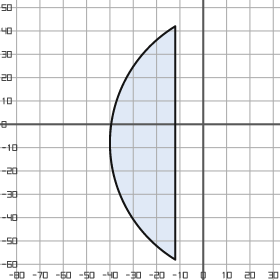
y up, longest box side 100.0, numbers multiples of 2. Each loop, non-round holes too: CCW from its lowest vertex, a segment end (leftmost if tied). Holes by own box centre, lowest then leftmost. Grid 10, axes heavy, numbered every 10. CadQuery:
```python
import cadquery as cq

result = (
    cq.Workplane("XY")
    .moveTo(-12.0, -58.0)
    .lineTo(-12.0, 42.0)
    .threePointArc((-40.0, -8.0), (-12.0, -58.0))
    .close()
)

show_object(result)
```